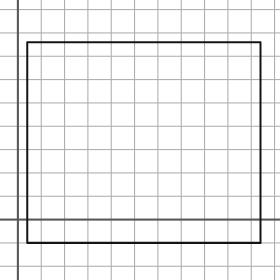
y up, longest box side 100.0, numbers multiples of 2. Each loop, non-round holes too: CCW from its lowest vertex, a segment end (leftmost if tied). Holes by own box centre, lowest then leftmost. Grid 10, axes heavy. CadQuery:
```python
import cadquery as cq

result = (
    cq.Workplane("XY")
    .moveTo(4.0, -10.0)
    .lineTo(104.0, -10.0)
    .lineTo(104.0, 76.0)
    .lineTo(4.0, 76.0)
    .close()
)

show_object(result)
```